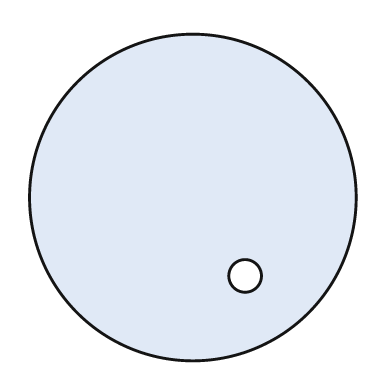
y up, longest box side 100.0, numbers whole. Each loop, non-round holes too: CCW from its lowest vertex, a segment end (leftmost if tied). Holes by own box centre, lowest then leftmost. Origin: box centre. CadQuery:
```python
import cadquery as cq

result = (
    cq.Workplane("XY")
    .moveTo(0.0, 0.0)
    .circle(50.0)
    .moveTo(16.0, -24.0)
    .circle(5.0)
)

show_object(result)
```